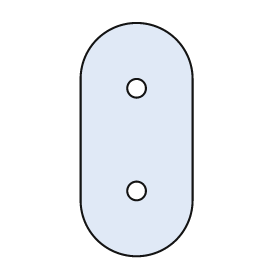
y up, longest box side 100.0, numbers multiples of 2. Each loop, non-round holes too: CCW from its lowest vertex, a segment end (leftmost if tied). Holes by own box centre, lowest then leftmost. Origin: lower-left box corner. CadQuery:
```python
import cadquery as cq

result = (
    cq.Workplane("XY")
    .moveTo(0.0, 24.0)
    .threePointArc((24.0, 0.0), (48.0, 24.0))
    .lineTo(48.0, 76.0)
    .threePointArc((24.0, 100.0), (0.0, 76.0))
    .close()
    .moveTo(24.0, 28.0)
    .circle(4.0)
    .moveTo(24.0, 72.0)
    .circle(4.0)
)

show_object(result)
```